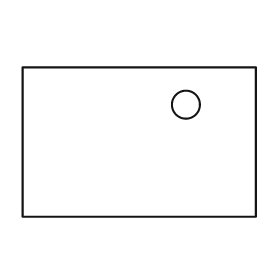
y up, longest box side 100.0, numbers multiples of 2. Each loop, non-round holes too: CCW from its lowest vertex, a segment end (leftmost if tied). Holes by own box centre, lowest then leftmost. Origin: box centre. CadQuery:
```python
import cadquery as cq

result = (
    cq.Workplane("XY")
    .moveTo(-50.0, -32.0)
    .lineTo(50.0, -32.0)
    .lineTo(50.0, 32.0)
    .lineTo(-50.0, 32.0)
    .close()
    .moveTo(20.0, 16.0)
    .circle(6.0)
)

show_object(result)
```